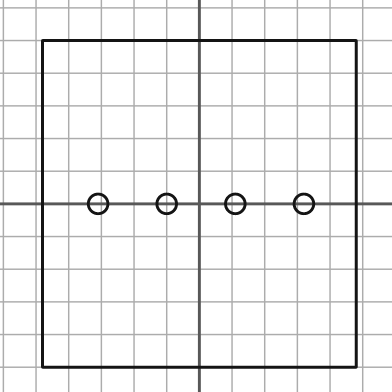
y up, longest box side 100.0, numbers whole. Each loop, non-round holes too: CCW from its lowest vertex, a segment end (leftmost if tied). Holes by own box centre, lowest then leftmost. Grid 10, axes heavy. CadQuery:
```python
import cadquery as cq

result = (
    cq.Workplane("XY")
    .moveTo(-48.0, -50.0)
    .lineTo(48.0, -50.0)
    .lineTo(48.0, 50.0)
    .lineTo(-48.0, 50.0)
    .close()
    .moveTo(-31.0, 0.0)
    .circle(3.0)
    .moveTo(-10.0, 0.0)
    .circle(3.0)
    .moveTo(11.0, 0.0)
    .circle(3.0)
    .moveTo(32.0, 0.0)
    .circle(3.0)
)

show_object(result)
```